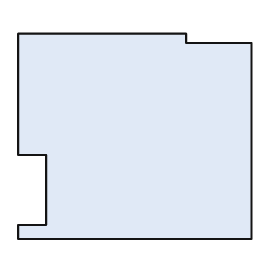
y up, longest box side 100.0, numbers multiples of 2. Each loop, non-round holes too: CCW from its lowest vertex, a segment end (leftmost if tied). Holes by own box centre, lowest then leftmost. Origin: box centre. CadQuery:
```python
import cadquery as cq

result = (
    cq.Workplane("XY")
    .moveTo(-50.0, -44.0)
    .lineTo(50.0, -44.0)
    .lineTo(50.0, 40.0)
    .lineTo(22.0, 40.0)
    .lineTo(22.0, 44.0)
    .lineTo(-50.0, 44.0)
    .lineTo(-50.0, -8.0)
    .lineTo(-38.0, -8.0)
    .lineTo(-38.0, -38.0)
    .lineTo(-50.0, -38.0)
    .close()
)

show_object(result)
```